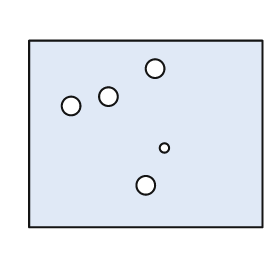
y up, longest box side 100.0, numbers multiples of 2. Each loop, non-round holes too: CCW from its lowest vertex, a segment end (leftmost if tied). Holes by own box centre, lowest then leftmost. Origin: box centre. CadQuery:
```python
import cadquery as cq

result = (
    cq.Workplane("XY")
    .moveTo(-50.0, -40.0)
    .lineTo(50.0, -40.0)
    .lineTo(50.0, 40.0)
    .lineTo(-50.0, 40.0)
    .close()
    .moveTo(0.0, -22.0)
    .circle(4.0)
    .moveTo(8.0, -6.0)
    .circle(2.0)
    .moveTo(-32.0, 12.0)
    .circle(4.0)
    .moveTo(-16.0, 16.0)
    .circle(4.0)
    .moveTo(4.0, 28.0)
    .circle(4.0)
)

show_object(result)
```